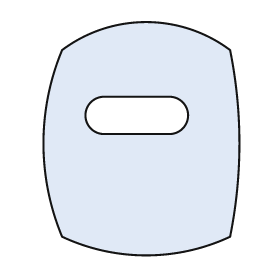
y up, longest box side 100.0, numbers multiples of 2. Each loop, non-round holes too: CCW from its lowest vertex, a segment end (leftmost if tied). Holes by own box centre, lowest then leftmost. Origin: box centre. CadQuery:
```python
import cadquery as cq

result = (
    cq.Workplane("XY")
    .moveTo(-34.0, -42.0)
    .threePointArc((2.0, -50.0), (38.0, -42.0))
    .threePointArc((42.0, -2.0), (38.0, 38.0))
    .threePointArc((2.0, 50.0), (-34.0, 38.0))
    .threePointArc((-42.0, -2.0), (-34.0, -42.0))
    .close()
    .moveTo(-16.0, 2.0)
    .lineTo(12.0, 2.0)
    .threePointArc((20.0, 10.0), (12.0, 18.0))
    .lineTo(-16.0, 18.0)
    .threePointArc((-24.0, 10.0), (-16.0, 2.0))
    .close()
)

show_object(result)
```